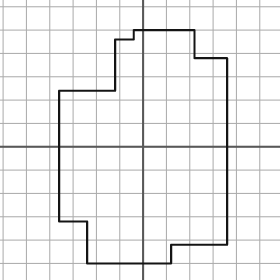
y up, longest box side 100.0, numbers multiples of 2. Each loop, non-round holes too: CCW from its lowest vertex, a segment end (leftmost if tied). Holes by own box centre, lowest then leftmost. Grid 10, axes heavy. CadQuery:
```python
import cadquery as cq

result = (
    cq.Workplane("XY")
    .moveTo(-24.0, -50.0)
    .lineTo(12.0, -50.0)
    .lineTo(12.0, -42.0)
    .lineTo(36.0, -42.0)
    .lineTo(36.0, 38.0)
    .lineTo(22.0, 38.0)
    .lineTo(22.0, 50.0)
    .lineTo(-4.0, 50.0)
    .lineTo(-4.0, 46.0)
    .lineTo(-12.0, 46.0)
    .lineTo(-12.0, 24.0)
    .lineTo(-36.0, 24.0)
    .lineTo(-36.0, -32.0)
    .lineTo(-24.0, -32.0)
    .close()
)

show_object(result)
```